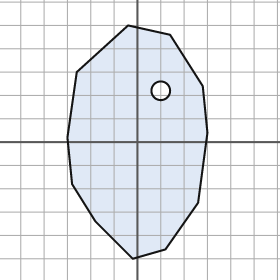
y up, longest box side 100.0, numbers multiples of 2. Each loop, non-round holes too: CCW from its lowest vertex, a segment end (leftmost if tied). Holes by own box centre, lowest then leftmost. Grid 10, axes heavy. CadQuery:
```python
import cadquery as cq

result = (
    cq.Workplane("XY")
    .moveTo(-2.0, -50.0)
    .lineTo(12.0, -46.0)
    .lineTo(26.0, -26.0)
    .lineTo(30.0, 4.0)
    .lineTo(28.0, 24.0)
    .lineTo(14.0, 46.0)
    .lineTo(-4.0, 50.0)
    .lineTo(-26.0, 30.0)
    .lineTo(-30.0, 2.0)
    .lineTo(-28.0, -18.0)
    .lineTo(-18.0, -34.0)
    .close()
    .moveTo(10.0, 22.0)
    .circle(4.0)
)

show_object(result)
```